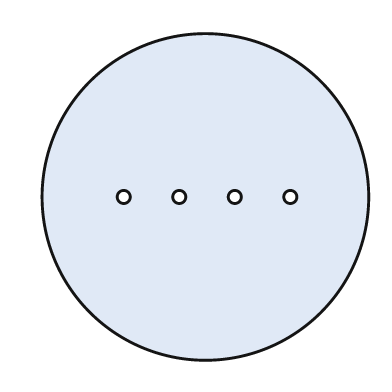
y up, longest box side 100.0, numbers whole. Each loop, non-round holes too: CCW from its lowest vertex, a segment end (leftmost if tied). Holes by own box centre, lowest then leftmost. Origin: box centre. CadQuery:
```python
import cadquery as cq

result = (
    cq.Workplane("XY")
    .moveTo(0.0, 0.0)
    .circle(50.0)
    .moveTo(-25.0, 0.0)
    .circle(2.0)
    .moveTo(-8.0, 0.0)
    .circle(2.0)
    .moveTo(9.0, 0.0)
    .circle(2.0)
    .moveTo(26.0, 0.0)
    .circle(2.0)
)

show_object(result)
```